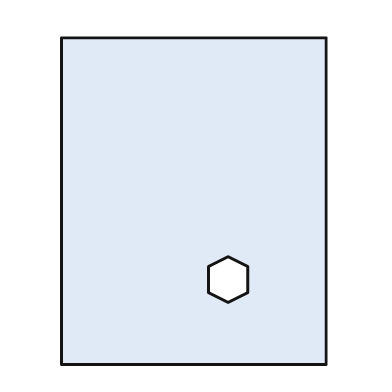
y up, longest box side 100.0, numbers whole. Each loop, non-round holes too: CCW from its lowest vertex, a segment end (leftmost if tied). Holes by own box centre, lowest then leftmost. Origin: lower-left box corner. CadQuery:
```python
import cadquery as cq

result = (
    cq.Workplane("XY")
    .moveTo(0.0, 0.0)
    .lineTo(81.0, 0.0)
    .lineTo(81.0, 100.0)
    .lineTo(0.0, 100.0)
    .close()
    .moveTo(51.0, 19.0)
    .lineTo(57.0, 22.0)
    .lineTo(57.0, 30.0)
    .lineTo(51.0, 33.0)
    .lineTo(45.0, 30.0)
    .lineTo(45.0, 22.0)
    .close()
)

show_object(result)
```